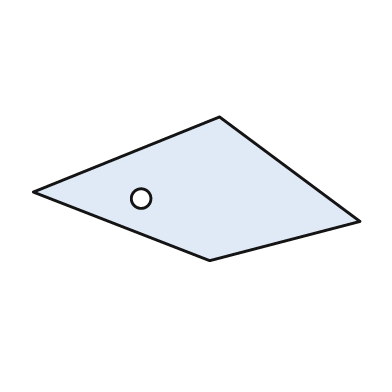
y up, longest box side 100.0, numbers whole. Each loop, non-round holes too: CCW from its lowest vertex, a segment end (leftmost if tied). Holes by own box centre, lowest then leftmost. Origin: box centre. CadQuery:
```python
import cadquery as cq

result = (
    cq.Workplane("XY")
    .moveTo(4.0, -22.0)
    .lineTo(50.0, -10.0)
    .lineTo(7.0, 22.0)
    .lineTo(-50.0, -1.0)
    .close()
    .moveTo(-17.0, -3.0)
    .circle(3.0)
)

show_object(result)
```